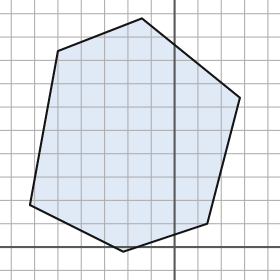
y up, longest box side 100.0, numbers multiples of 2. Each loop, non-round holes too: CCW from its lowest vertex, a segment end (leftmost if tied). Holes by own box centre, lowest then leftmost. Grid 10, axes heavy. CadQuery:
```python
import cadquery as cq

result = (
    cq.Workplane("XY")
    .moveTo(-22.0, -2.0)
    .lineTo(14.0, 10.0)
    .lineTo(28.0, 64.0)
    .lineTo(-14.0, 98.0)
    .lineTo(-50.0, 84.0)
    .lineTo(-62.0, 18.0)
    .close()
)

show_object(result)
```